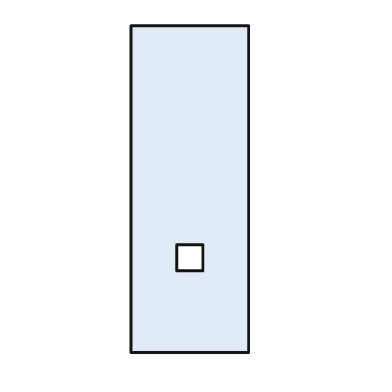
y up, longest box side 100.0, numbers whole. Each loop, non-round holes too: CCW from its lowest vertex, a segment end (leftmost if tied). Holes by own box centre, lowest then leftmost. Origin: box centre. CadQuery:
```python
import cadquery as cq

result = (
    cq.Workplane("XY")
    .moveTo(-18.0, -50.0)
    .lineTo(18.0, -50.0)
    .lineTo(18.0, 50.0)
    .lineTo(-18.0, 50.0)
    .close()
    .moveTo(-4.0, -25.0)
    .lineTo(4.0, -25.0)
    .lineTo(4.0, -17.0)
    .lineTo(-4.0, -17.0)
    .close()
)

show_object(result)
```